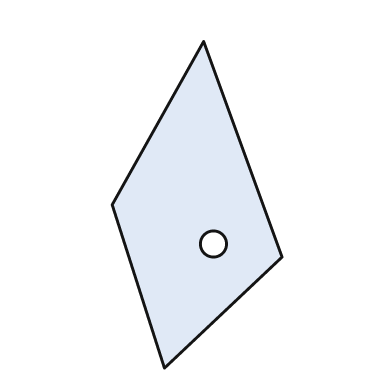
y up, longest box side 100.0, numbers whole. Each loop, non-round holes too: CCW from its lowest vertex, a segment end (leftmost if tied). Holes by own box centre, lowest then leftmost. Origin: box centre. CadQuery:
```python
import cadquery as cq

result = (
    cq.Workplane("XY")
    .moveTo(-10.0, -50.0)
    .lineTo(26.0, -16.0)
    .lineTo(2.0, 50.0)
    .lineTo(-26.0, 0.0)
    .close()
    .moveTo(5.0, -12.0)
    .circle(4.0)
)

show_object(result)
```